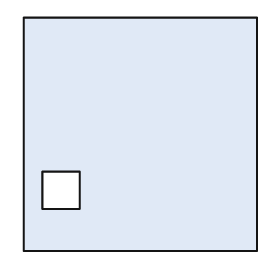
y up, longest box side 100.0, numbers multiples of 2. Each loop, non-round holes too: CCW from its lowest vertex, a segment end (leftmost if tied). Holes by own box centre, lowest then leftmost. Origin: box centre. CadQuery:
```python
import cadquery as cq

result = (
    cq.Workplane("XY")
    .moveTo(-50.0, -50.0)
    .lineTo(50.0, -50.0)
    .lineTo(50.0, 50.0)
    .lineTo(-50.0, 50.0)
    .close()
    .moveTo(-42.0, -32.0)
    .lineTo(-26.0, -32.0)
    .lineTo(-26.0, -16.0)
    .lineTo(-42.0, -16.0)
    .close()
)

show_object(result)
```